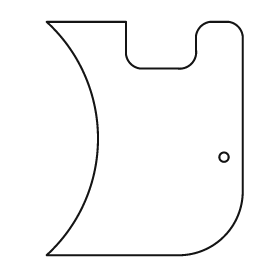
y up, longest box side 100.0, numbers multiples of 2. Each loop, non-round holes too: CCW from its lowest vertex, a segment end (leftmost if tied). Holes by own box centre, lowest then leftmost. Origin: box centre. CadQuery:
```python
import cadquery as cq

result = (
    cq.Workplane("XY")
    .moveTo(-42.0, -50.0)
    .lineTo(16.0, -50.0)
    .threePointArc((34.0, -42.0), (42.0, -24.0))
    .lineTo(42.0, 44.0)
    .threePointArc((40.0, 48.0), (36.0, 50.0))
    .lineTo(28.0, 50.0)
    .threePointArc((24.0, 48.0), (22.0, 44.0))
    .lineTo(22.0, 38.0)
    .threePointArc((20.0, 32.0), (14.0, 30.0))
    .lineTo(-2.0, 30.0)
    .threePointArc((-6.0, 32.0), (-8.0, 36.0))
    .lineTo(-8.0, 50.0)
    .lineTo(-42.0, 50.0)
    .threePointArc((-20.0, 0.0), (-42.0, -50.0))
    .close()
    .moveTo(34.0, -8.0)
    .circle(2.0)
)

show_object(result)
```